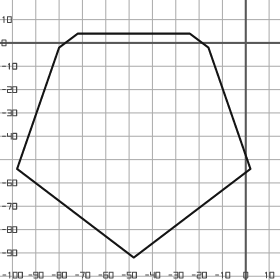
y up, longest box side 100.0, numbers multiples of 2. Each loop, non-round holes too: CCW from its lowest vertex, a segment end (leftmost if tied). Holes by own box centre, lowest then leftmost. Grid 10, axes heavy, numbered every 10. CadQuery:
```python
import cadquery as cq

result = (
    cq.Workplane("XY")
    .moveTo(-48.0, -92.0)
    .lineTo(2.0, -54.0)
    .lineTo(-16.0, -2.0)
    .lineTo(-24.0, 4.0)
    .lineTo(-72.0, 4.0)
    .lineTo(-80.0, -2.0)
    .lineTo(-98.0, -54.0)
    .close()
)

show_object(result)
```